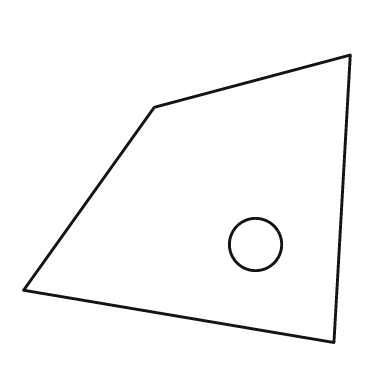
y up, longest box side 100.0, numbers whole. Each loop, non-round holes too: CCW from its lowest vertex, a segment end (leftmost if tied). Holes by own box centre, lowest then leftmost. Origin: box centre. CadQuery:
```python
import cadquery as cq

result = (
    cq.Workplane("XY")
    .moveTo(45.0, -44.0)
    .lineTo(50.0, 44.0)
    .lineTo(-10.0, 28.0)
    .lineTo(-50.0, -28.0)
    .close()
    .moveTo(21.0, -14.0)
    .circle(8.0)
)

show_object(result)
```